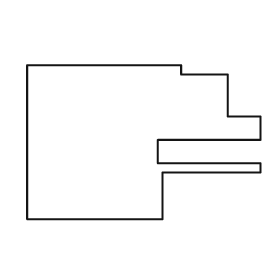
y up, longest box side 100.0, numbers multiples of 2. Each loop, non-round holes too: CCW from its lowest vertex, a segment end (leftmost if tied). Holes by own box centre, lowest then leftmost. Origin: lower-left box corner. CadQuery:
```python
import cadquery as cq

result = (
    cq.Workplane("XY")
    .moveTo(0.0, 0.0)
    .lineTo(58.0, 0.0)
    .lineTo(58.0, 20.0)
    .lineTo(100.0, 20.0)
    .lineTo(100.0, 24.0)
    .lineTo(56.0, 24.0)
    .lineTo(56.0, 34.0)
    .lineTo(100.0, 34.0)
    .lineTo(100.0, 44.0)
    .lineTo(86.0, 44.0)
    .lineTo(86.0, 62.0)
    .lineTo(66.0, 62.0)
    .lineTo(66.0, 66.0)
    .lineTo(0.0, 66.0)
    .close()
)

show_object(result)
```